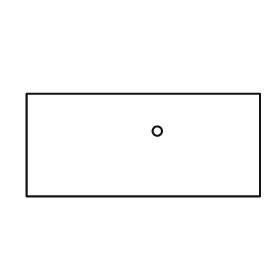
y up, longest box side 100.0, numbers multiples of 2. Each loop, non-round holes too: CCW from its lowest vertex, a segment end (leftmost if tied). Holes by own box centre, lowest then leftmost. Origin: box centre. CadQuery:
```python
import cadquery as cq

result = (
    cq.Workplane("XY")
    .moveTo(-50.0, -22.0)
    .lineTo(50.0, -22.0)
    .lineTo(50.0, 22.0)
    .lineTo(-50.0, 22.0)
    .close()
    .moveTo(6.0, 6.0)
    .circle(2.0)
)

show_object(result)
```